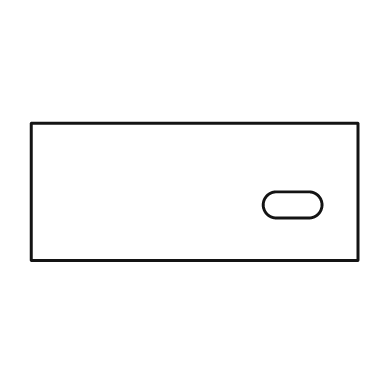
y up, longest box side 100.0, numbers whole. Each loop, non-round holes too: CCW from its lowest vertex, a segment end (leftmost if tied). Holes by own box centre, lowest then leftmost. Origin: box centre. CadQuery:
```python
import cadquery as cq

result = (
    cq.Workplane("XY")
    .moveTo(-50.0, -21.0)
    .lineTo(50.0, -21.0)
    .lineTo(50.0, 21.0)
    .lineTo(-50.0, 21.0)
    .close()
    .moveTo(25.0, -8.0)
    .lineTo(35.0, -8.0)
    .threePointArc((39.0, -4.0), (35.0, 0.0))
    .lineTo(25.0, 0.0)
    .threePointArc((21.0, -4.0), (25.0, -8.0))
    .close()
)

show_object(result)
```